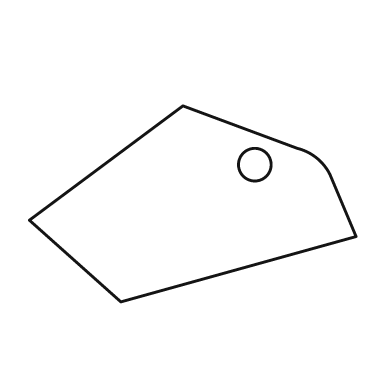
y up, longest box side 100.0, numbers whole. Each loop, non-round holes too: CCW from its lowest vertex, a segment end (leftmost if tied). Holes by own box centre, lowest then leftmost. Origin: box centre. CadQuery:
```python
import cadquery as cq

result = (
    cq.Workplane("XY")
    .moveTo(-22.0, -30.0)
    .lineTo(50.0, -10.0)
    .lineTo(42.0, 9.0)
    .threePointArc((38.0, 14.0), (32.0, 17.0))
    .lineTo(-3.0, 30.0)
    .lineTo(-50.0, -5.0)
    .close()
    .moveTo(19.0, 12.0)
    .circle(5.0)
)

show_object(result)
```